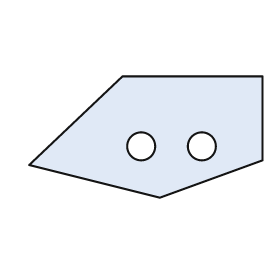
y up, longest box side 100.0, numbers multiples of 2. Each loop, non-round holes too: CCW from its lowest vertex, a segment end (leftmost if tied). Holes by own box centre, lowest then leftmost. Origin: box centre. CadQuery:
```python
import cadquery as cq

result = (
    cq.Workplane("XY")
    .moveTo(6.0, -26.0)
    .lineTo(50.0, -10.0)
    .lineTo(50.0, 26.0)
    .lineTo(-10.0, 26.0)
    .lineTo(-50.0, -12.0)
    .close()
    .moveTo(-2.0, -4.0)
    .circle(6.0)
    .moveTo(24.0, -4.0)
    .circle(6.0)
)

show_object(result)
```